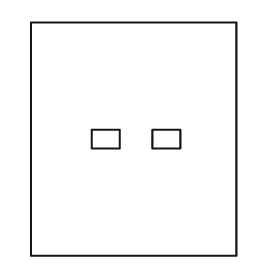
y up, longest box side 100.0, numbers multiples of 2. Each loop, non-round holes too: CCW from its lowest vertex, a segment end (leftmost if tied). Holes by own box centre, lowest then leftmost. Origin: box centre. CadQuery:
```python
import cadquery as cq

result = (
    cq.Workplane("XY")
    .moveTo(-44.0, -50.0)
    .lineTo(44.0, -50.0)
    .lineTo(44.0, 50.0)
    .lineTo(-44.0, 50.0)
    .close()
    .moveTo(-18.0, -4.0)
    .lineTo(-6.0, -4.0)
    .lineTo(-6.0, 4.0)
    .lineTo(-18.0, 4.0)
    .close()
    .moveTo(8.0, -4.0)
    .lineTo(20.0, -4.0)
    .lineTo(20.0, 4.0)
    .lineTo(8.0, 4.0)
    .close()
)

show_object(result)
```